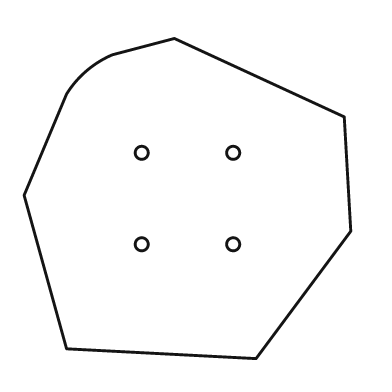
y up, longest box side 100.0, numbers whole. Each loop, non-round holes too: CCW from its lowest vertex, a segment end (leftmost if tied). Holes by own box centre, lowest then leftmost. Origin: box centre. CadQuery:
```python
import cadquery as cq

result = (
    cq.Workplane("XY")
    .moveTo(21.0, -49.0)
    .lineTo(50.0, -10.0)
    .lineTo(48.0, 25.0)
    .lineTo(-4.0, 49.0)
    .lineTo(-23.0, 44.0)
    .threePointArc((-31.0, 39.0), (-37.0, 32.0))
    .lineTo(-50.0, 1.0)
    .lineTo(-37.0, -46.0)
    .close()
    .moveTo(-14.0, -14.0)
    .circle(2.0)
    .moveTo(14.0, -14.0)
    .circle(2.0)
    .moveTo(-14.0, 14.0)
    .circle(2.0)
    .moveTo(14.0, 14.0)
    .circle(2.0)
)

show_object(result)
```